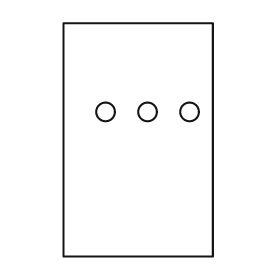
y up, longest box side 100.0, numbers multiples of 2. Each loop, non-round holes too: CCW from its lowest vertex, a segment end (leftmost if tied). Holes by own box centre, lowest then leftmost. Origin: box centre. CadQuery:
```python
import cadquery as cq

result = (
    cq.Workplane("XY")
    .moveTo(-32.0, -50.0)
    .lineTo(32.0, -50.0)
    .lineTo(32.0, 50.0)
    .lineTo(-32.0, 50.0)
    .close()
    .moveTo(-14.0, 12.0)
    .circle(4.0)
    .moveTo(4.0, 12.0)
    .circle(4.0)
    .moveTo(22.0, 12.0)
    .circle(4.0)
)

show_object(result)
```